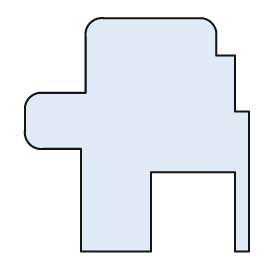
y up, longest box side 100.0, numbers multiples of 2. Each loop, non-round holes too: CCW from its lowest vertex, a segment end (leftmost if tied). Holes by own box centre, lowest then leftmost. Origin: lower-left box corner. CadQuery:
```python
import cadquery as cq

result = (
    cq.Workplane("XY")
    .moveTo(24.0, 0.0)
    .lineTo(54.0, 0.0)
    .lineTo(54.0, 34.0)
    .lineTo(90.0, 34.0)
    .lineTo(90.0, 0.0)
    .lineTo(96.0, 0.0)
    .lineTo(96.0, 60.0)
    .lineTo(90.0, 60.0)
    .lineTo(90.0, 84.0)
    .lineTo(82.0, 84.0)
    .lineTo(82.0, 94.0)
    .threePointArc((80.0, 98.0), (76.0, 100.0))
    .lineTo(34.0, 100.0)
    .threePointArc((28.0, 98.0), (26.0, 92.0))
    .lineTo(26.0, 68.0)
    .lineTo(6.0, 68.0)
    .threePointArc((2.0, 66.0), (0.0, 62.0))
    .lineTo(0.0, 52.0)
    .threePointArc((2.0, 46.0), (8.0, 44.0))
    .lineTo(24.0, 44.0)
    .close()
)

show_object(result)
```